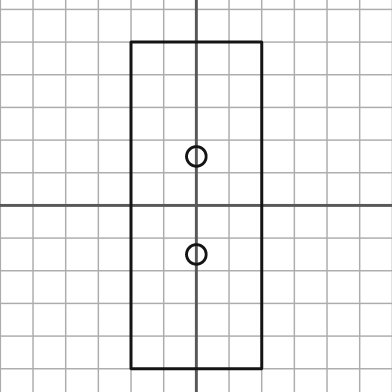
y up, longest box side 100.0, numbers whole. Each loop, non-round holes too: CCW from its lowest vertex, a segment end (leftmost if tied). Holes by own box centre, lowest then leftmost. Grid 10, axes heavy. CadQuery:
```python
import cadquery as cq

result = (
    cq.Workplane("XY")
    .moveTo(-20.0, -50.0)
    .lineTo(20.0, -50.0)
    .lineTo(20.0, 50.0)
    .lineTo(-20.0, 50.0)
    .close()
    .moveTo(0.0, -15.0)
    .circle(3.0)
    .moveTo(0.0, 15.0)
    .circle(3.0)
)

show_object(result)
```